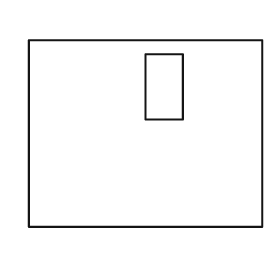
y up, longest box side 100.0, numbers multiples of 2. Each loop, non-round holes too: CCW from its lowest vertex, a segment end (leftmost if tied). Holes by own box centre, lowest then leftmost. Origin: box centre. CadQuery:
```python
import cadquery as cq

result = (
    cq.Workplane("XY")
    .moveTo(-50.0, -40.0)
    .lineTo(50.0, -40.0)
    .lineTo(50.0, 40.0)
    .lineTo(-50.0, 40.0)
    .close()
    .moveTo(0.0, 6.0)
    .lineTo(16.0, 6.0)
    .lineTo(16.0, 34.0)
    .lineTo(0.0, 34.0)
    .close()
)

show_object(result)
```